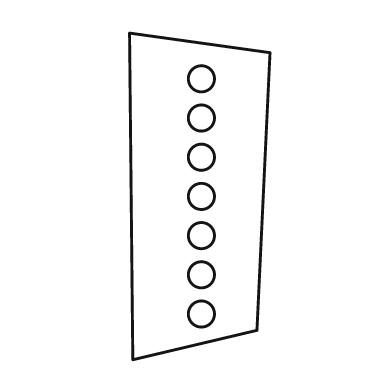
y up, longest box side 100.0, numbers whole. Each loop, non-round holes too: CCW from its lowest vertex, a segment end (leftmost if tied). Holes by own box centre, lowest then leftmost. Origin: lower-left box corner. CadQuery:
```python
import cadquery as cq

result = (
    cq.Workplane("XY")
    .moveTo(1.0, 0.0)
    .lineTo(39.0, 9.0)
    .lineTo(43.0, 94.0)
    .lineTo(0.0, 100.0)
    .close()
    .moveTo(22.0, 14.0)
    .circle(4.0)
    .moveTo(22.0, 26.0)
    .circle(4.0)
    .moveTo(22.0, 38.0)
    .circle(4.0)
    .moveTo(22.0, 50.0)
    .circle(4.0)
    .moveTo(22.0, 62.0)
    .circle(4.0)
    .moveTo(22.0, 74.0)
    .circle(4.0)
    .moveTo(22.0, 86.0)
    .circle(4.0)
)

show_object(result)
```